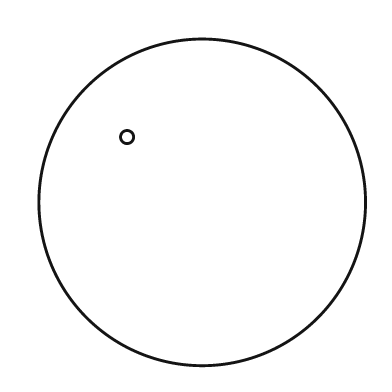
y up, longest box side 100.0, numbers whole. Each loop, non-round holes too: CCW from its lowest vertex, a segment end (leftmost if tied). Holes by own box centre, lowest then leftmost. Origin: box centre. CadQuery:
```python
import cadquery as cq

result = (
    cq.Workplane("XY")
    .moveTo(0.0, 0.0)
    .circle(50.0)
    .moveTo(-23.0, 20.0)
    .circle(2.0)
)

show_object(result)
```